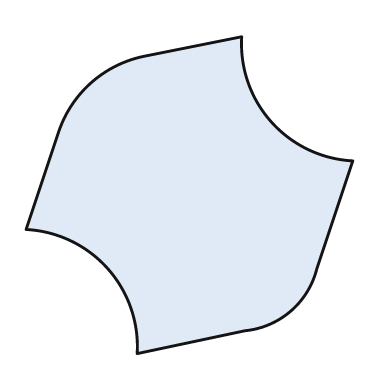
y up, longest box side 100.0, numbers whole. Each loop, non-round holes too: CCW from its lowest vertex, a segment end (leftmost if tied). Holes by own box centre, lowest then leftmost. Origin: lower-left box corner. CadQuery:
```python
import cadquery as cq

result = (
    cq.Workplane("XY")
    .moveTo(34.0, 0.0)
    .lineTo(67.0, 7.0)
    .threePointArc((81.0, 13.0), (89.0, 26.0))
    .lineTo(100.0, 59.0)
    .threePointArc((75.0, 71.0), (66.0, 97.0))
    .lineTo(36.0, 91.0)
    .threePointArc((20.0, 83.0), (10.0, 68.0))
    .lineTo(0.0, 38.0)
    .threePointArc((25.0, 26.0), (34.0, 0.0))
    .close()
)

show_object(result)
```